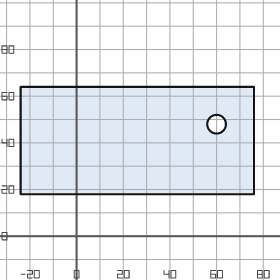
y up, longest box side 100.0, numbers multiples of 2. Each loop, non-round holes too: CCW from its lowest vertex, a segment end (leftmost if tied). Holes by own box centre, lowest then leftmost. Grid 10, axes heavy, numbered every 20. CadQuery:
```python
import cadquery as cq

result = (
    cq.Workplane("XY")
    .moveTo(-24.0, 18.0)
    .lineTo(76.0, 18.0)
    .lineTo(76.0, 64.0)
    .lineTo(-24.0, 64.0)
    .close()
    .moveTo(60.0, 48.0)
    .circle(4.0)
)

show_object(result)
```